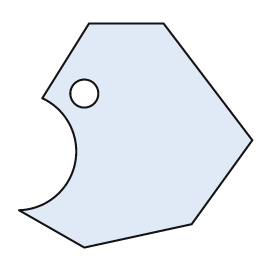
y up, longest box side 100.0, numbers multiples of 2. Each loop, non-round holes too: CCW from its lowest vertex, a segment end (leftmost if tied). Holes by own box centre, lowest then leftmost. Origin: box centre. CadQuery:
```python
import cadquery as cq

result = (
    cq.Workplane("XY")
    .moveTo(-22.0, -48.0)
    .lineTo(24.0, -38.0)
    .lineTo(50.0, -2.0)
    .lineTo(12.0, 48.0)
    .lineTo(-20.0, 48.0)
    .lineTo(-40.0, 16.0)
    .threePointArc((-26.0, -12.0), (-50.0, -32.0))
    .close()
    .moveTo(-22.0, 18.0)
    .circle(6.0)
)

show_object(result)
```